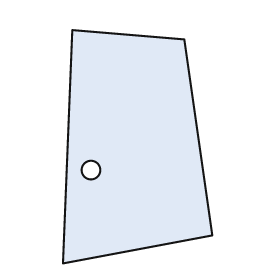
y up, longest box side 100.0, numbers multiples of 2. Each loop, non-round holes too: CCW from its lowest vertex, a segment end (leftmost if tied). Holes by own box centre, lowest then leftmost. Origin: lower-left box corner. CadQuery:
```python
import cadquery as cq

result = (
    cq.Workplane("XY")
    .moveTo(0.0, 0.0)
    .lineTo(64.0, 12.0)
    .lineTo(52.0, 96.0)
    .lineTo(4.0, 100.0)
    .close()
    .moveTo(12.0, 40.0)
    .circle(4.0)
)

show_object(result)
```